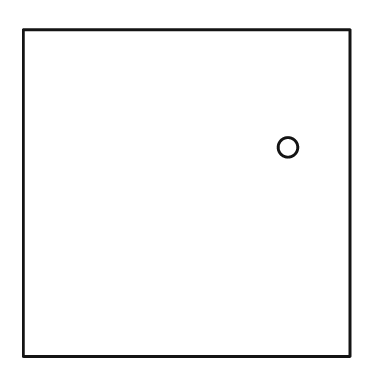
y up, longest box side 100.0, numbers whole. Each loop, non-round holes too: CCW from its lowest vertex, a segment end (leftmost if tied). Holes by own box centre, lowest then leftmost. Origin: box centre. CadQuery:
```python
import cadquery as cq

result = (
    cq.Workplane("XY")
    .moveTo(-50.0, -50.0)
    .lineTo(50.0, -50.0)
    .lineTo(50.0, 50.0)
    .lineTo(-50.0, 50.0)
    .close()
    .moveTo(31.0, 14.0)
    .circle(3.0)
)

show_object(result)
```